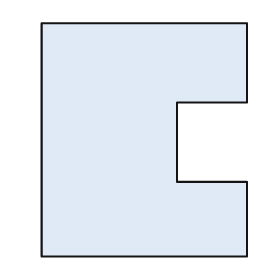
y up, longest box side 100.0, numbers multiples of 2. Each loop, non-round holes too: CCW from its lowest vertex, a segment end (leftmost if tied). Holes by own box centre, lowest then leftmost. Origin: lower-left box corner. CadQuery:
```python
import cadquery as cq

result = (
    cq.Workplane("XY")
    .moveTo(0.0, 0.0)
    .lineTo(88.0, 0.0)
    .lineTo(88.0, 32.0)
    .lineTo(58.0, 32.0)
    .lineTo(58.0, 66.0)
    .lineTo(88.0, 66.0)
    .lineTo(88.0, 100.0)
    .lineTo(0.0, 100.0)
    .close()
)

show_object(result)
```